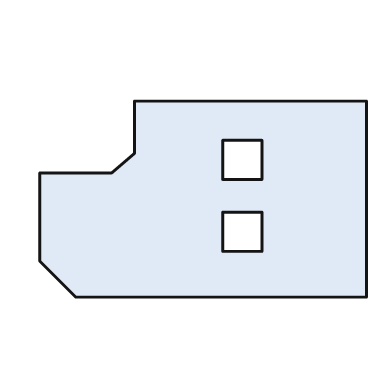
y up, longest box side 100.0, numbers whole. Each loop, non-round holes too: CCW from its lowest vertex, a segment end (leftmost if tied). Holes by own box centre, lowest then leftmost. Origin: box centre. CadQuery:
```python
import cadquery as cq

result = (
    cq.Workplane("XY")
    .moveTo(-39.0, -30.0)
    .lineTo(50.0, -30.0)
    .lineTo(50.0, 30.0)
    .lineTo(-21.0, 30.0)
    .lineTo(-21.0, 14.0)
    .lineTo(-28.0, 8.0)
    .lineTo(-50.0, 8.0)
    .lineTo(-50.0, -19.0)
    .close()
    .moveTo(6.0, -16.0)
    .lineTo(18.0, -16.0)
    .lineTo(18.0, -4.0)
    .lineTo(6.0, -4.0)
    .close()
    .moveTo(6.0, 6.0)
    .lineTo(18.0, 6.0)
    .lineTo(18.0, 18.0)
    .lineTo(6.0, 18.0)
    .close()
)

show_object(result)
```